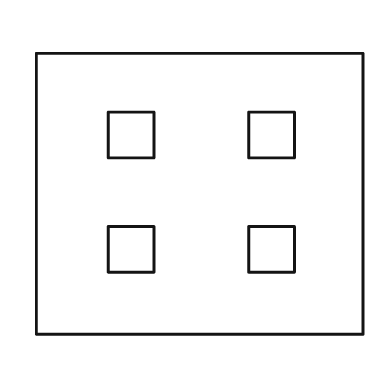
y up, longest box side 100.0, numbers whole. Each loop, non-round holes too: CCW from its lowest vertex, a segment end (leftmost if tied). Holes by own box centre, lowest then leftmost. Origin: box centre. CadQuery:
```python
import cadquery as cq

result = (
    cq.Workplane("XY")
    .moveTo(-50.0, -43.0)
    .lineTo(50.0, -43.0)
    .lineTo(50.0, 43.0)
    .lineTo(-50.0, 43.0)
    .close()
    .moveTo(-28.0, -24.0)
    .lineTo(-14.0, -24.0)
    .lineTo(-14.0, -10.0)
    .lineTo(-28.0, -10.0)
    .close()
    .moveTo(15.0, -24.0)
    .lineTo(29.0, -24.0)
    .lineTo(29.0, -10.0)
    .lineTo(15.0, -10.0)
    .close()
    .moveTo(-28.0, 11.0)
    .lineTo(-14.0, 11.0)
    .lineTo(-14.0, 25.0)
    .lineTo(-28.0, 25.0)
    .close()
    .moveTo(15.0, 11.0)
    .lineTo(29.0, 11.0)
    .lineTo(29.0, 25.0)
    .lineTo(15.0, 25.0)
    .close()
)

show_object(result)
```